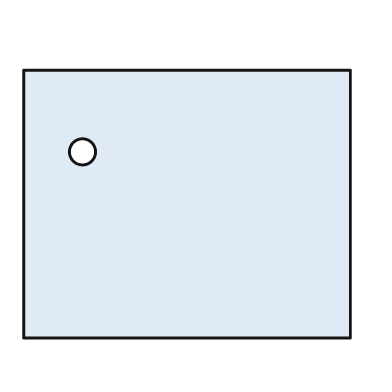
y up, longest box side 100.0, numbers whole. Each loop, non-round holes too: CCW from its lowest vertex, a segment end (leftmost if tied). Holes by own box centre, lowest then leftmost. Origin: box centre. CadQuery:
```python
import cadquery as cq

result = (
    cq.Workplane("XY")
    .moveTo(-50.0, -41.0)
    .lineTo(50.0, -41.0)
    .lineTo(50.0, 41.0)
    .lineTo(-50.0, 41.0)
    .close()
    .moveTo(-32.0, 16.0)
    .circle(4.0)
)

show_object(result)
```